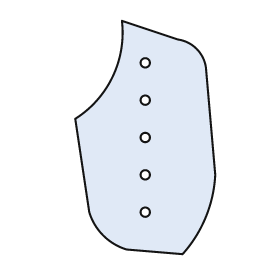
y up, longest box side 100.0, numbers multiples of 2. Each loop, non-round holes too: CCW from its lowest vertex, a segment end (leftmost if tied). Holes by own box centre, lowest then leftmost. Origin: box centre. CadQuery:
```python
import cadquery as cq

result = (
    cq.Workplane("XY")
    .moveTo(16.0, -50.0)
    .threePointArc((26.0, -34.0), (30.0, -16.0))
    .lineTo(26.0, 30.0)
    .threePointArc((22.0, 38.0), (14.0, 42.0))
    .lineTo(-10.0, 50.0)
    .threePointArc((-14.0, 26.0), (-30.0, 8.0))
    .lineTo(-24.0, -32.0)
    .threePointArc((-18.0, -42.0), (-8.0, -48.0))
    .close()
    .moveTo(0.0, -32.0)
    .circle(2.0)
    .moveTo(0.0, -16.0)
    .circle(2.0)
    .moveTo(0.0, 0.0)
    .circle(2.0)
    .moveTo(0.0, 16.0)
    .circle(2.0)
    .moveTo(0.0, 32.0)
    .circle(2.0)
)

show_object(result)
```